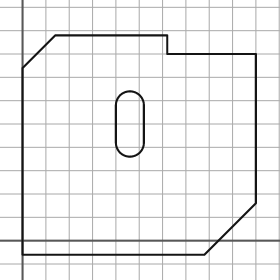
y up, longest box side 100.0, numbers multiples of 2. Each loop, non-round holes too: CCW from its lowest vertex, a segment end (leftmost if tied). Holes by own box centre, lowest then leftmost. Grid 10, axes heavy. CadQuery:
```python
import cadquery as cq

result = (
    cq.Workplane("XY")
    .moveTo(0.0, -6.0)
    .lineTo(78.0, -6.0)
    .lineTo(100.0, 16.0)
    .lineTo(100.0, 80.0)
    .lineTo(62.0, 80.0)
    .lineTo(62.0, 88.0)
    .lineTo(14.0, 88.0)
    .lineTo(0.0, 74.0)
    .close()
    .moveTo(40.0, 42.0)
    .threePointArc((46.0, 36.0), (52.0, 42.0))
    .lineTo(52.0, 58.0)
    .threePointArc((46.0, 64.0), (40.0, 58.0))
    .close()
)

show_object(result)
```